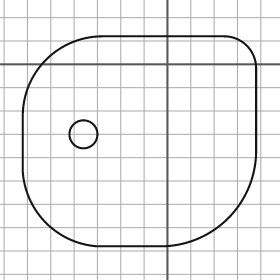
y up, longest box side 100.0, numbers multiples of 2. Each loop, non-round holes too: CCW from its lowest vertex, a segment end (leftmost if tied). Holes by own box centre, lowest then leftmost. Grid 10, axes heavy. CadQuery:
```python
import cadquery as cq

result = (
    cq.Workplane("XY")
    .moveTo(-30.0, -78.0)
    .lineTo(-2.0, -78.0)
    .threePointArc((26.0, -66.0), (38.0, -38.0))
    .lineTo(38.0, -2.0)
    .threePointArc((34.0, 8.0), (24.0, 12.0))
    .lineTo(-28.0, 12.0)
    .threePointArc((-52.0, 2.0), (-62.0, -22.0))
    .lineTo(-62.0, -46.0)
    .threePointArc((-52.0, -68.0), (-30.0, -78.0))
    .close()
    .moveTo(-36.0, -30.0)
    .circle(6.0)
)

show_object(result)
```